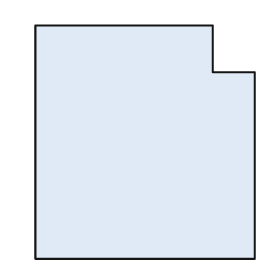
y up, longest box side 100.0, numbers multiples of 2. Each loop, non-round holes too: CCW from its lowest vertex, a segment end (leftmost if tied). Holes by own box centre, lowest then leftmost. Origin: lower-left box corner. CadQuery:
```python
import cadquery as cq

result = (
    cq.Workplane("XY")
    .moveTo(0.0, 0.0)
    .lineTo(94.0, 0.0)
    .lineTo(94.0, 80.0)
    .lineTo(76.0, 80.0)
    .lineTo(76.0, 100.0)
    .lineTo(0.0, 100.0)
    .close()
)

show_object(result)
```